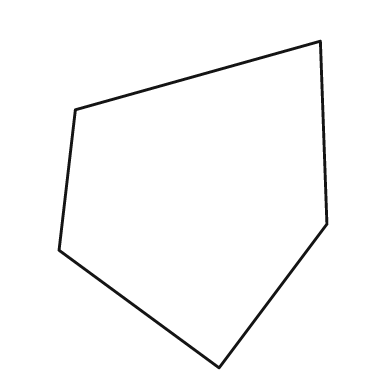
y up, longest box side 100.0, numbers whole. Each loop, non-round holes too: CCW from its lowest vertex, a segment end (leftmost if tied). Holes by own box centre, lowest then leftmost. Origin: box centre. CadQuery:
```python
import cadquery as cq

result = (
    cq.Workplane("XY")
    .moveTo(8.0, -50.0)
    .lineTo(41.0, -6.0)
    .lineTo(39.0, 50.0)
    .lineTo(-36.0, 29.0)
    .lineTo(-41.0, -14.0)
    .close()
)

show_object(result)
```